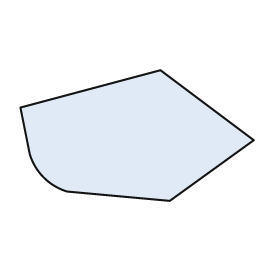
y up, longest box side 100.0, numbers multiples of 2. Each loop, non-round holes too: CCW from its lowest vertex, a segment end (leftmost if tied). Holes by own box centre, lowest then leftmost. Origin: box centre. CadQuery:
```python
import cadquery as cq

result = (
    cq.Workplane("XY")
    .moveTo(14.0, -28.0)
    .lineTo(50.0, -2.0)
    .lineTo(10.0, 28.0)
    .lineTo(-50.0, 12.0)
    .lineTo(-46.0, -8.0)
    .threePointArc((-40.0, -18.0), (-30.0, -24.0))
    .close()
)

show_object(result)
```